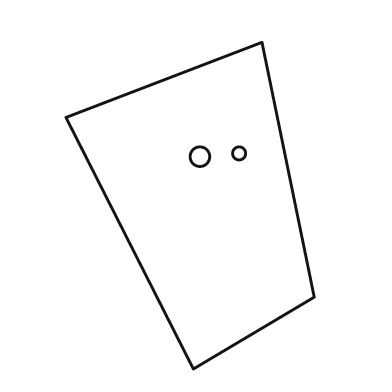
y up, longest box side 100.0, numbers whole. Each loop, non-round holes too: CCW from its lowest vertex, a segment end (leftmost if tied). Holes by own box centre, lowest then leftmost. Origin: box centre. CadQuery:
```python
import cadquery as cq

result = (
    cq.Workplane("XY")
    .moveTo(1.0, -50.0)
    .lineTo(38.0, -28.0)
    .lineTo(22.0, 50.0)
    .lineTo(-38.0, 27.0)
    .close()
    .moveTo(3.0, 15.0)
    .circle(3.0)
    .moveTo(15.0, 16.0)
    .circle(2.0)
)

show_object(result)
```